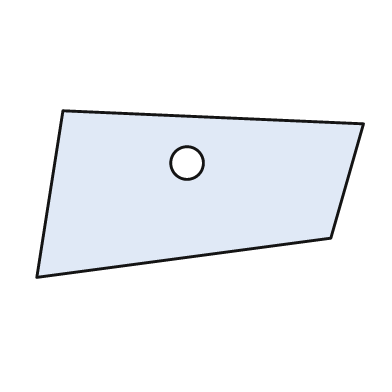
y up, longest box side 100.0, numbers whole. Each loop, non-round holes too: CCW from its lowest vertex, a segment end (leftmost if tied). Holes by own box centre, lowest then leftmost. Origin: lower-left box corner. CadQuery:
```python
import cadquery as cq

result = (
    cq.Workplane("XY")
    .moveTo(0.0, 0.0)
    .lineTo(90.0, 12.0)
    .lineTo(100.0, 47.0)
    .lineTo(8.0, 51.0)
    .close()
    .moveTo(46.0, 35.0)
    .circle(5.0)
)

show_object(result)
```